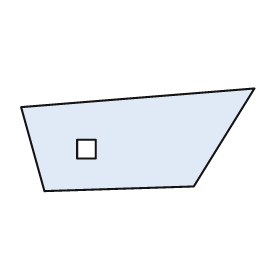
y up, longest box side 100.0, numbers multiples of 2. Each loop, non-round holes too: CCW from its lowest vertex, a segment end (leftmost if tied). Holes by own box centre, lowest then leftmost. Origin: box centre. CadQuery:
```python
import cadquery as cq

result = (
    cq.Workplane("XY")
    .moveTo(-40.0, -22.0)
    .lineTo(24.0, -20.0)
    .lineTo(50.0, 22.0)
    .lineTo(-50.0, 14.0)
    .close()
    .moveTo(-26.0, -8.0)
    .lineTo(-18.0, -8.0)
    .lineTo(-18.0, 0.0)
    .lineTo(-26.0, 0.0)
    .close()
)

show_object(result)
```